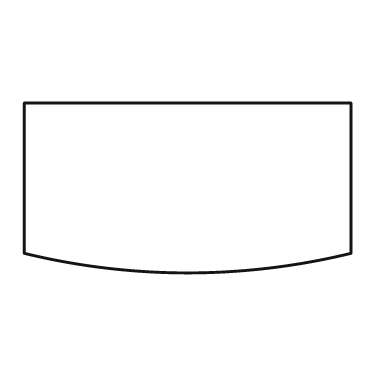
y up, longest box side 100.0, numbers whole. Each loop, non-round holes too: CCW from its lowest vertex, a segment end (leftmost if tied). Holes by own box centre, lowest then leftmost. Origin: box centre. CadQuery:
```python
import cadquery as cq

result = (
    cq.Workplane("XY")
    .moveTo(-50.0, -20.0)
    .threePointArc((0.0, -26.0), (50.0, -20.0))
    .lineTo(50.0, 26.0)
    .lineTo(-50.0, 26.0)
    .close()
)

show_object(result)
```